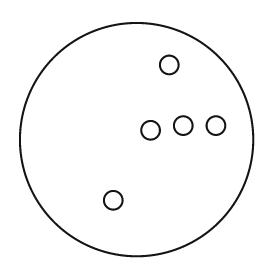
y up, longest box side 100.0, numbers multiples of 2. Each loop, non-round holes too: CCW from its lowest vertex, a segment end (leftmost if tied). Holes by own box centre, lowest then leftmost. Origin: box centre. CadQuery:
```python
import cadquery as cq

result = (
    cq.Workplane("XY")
    .moveTo(0.0, 0.0)
    .circle(50.0)
    .moveTo(-10.0, -26.0)
    .circle(4.0)
    .moveTo(6.0, 4.0)
    .circle(4.0)
    .moveTo(20.0, 6.0)
    .circle(4.0)
    .moveTo(34.0, 6.0)
    .circle(4.0)
    .moveTo(14.0, 32.0)
    .circle(4.0)
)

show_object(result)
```